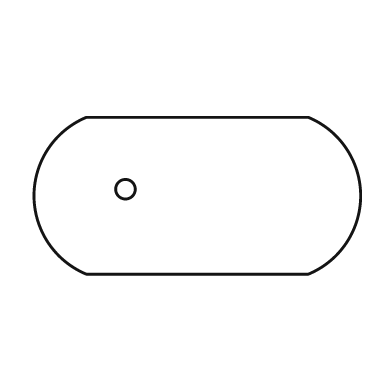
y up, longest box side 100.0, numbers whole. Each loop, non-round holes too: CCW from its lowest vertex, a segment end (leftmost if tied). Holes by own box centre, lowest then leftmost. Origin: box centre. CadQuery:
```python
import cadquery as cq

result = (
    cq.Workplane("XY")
    .moveTo(-34.0, -24.0)
    .lineTo(34.0, -24.0)
    .threePointArc((50.0, 0.0), (34.0, 24.0))
    .lineTo(-34.0, 24.0)
    .threePointArc((-50.0, 0.0), (-34.0, -24.0))
    .close()
    .moveTo(-22.0, 2.0)
    .circle(3.0)
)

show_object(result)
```